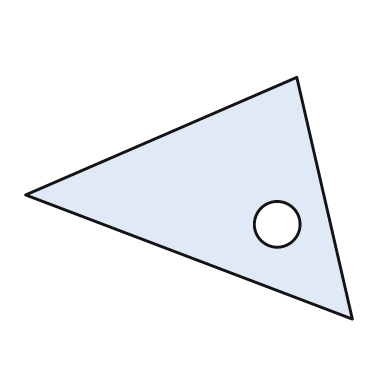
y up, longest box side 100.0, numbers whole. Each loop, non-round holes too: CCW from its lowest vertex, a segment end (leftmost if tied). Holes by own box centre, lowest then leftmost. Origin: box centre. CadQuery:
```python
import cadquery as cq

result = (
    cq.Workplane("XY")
    .moveTo(50.0, -37.0)
    .lineTo(33.0, 37.0)
    .lineTo(-50.0, 1.0)
    .close()
    .moveTo(27.0, -8.0)
    .circle(7.0)
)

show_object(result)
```